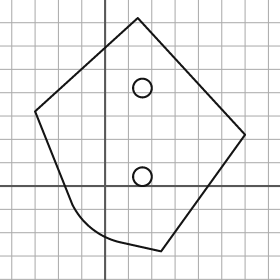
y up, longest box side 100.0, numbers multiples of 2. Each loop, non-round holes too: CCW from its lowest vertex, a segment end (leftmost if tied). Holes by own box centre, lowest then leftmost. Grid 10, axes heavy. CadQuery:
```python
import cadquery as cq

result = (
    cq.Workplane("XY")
    .moveTo(24.0, -28.0)
    .lineTo(60.0, 22.0)
    .lineTo(14.0, 72.0)
    .lineTo(-30.0, 32.0)
    .lineTo(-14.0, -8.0)
    .threePointArc((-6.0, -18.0), (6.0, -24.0))
    .close()
    .moveTo(16.0, 4.0)
    .circle(4.0)
    .moveTo(16.0, 42.0)
    .circle(4.0)
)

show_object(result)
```